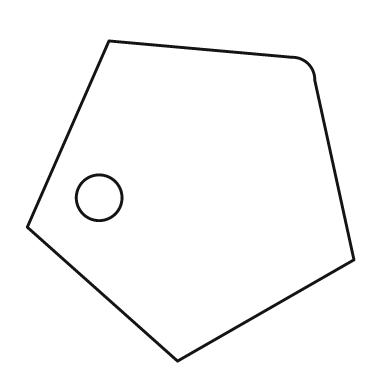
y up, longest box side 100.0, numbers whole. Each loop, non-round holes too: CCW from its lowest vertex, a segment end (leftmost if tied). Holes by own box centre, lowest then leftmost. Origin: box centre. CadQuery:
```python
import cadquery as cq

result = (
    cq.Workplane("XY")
    .moveTo(-4.0, -49.0)
    .lineTo(50.0, -18.0)
    .lineTo(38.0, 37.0)
    .threePointArc((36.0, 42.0), (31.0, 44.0))
    .lineTo(-25.0, 49.0)
    .lineTo(-50.0, -8.0)
    .close()
    .moveTo(-28.0, 1.0)
    .circle(7.0)
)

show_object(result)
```